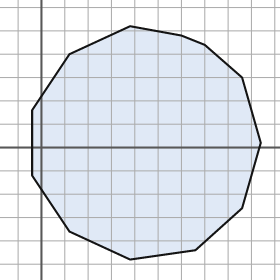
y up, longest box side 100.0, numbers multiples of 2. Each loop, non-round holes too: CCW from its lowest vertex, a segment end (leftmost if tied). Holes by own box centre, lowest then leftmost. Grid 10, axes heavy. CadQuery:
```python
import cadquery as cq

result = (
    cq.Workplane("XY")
    .moveTo(38.0, -48.0)
    .lineTo(66.0, -44.0)
    .lineTo(86.0, -26.0)
    .lineTo(94.0, 2.0)
    .lineTo(86.0, 30.0)
    .lineTo(70.0, 44.0)
    .lineTo(60.0, 48.0)
    .lineTo(38.0, 52.0)
    .lineTo(12.0, 40.0)
    .lineTo(-4.0, 16.0)
    .lineTo(-4.0, -12.0)
    .lineTo(12.0, -36.0)
    .close()
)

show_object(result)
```